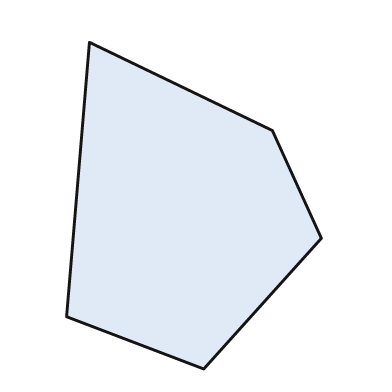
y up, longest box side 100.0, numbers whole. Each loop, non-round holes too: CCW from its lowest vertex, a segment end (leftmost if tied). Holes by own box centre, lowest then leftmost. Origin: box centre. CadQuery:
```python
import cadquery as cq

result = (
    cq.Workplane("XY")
    .moveTo(3.0, -50.0)
    .lineTo(39.0, -10.0)
    .lineTo(24.0, 23.0)
    .lineTo(-32.0, 50.0)
    .lineTo(-39.0, -34.0)
    .close()
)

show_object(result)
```